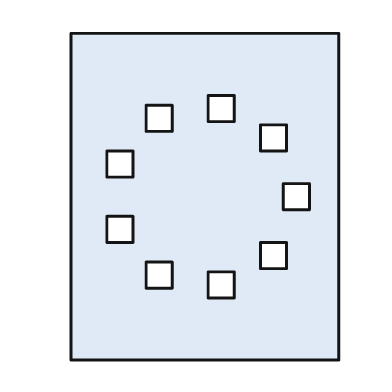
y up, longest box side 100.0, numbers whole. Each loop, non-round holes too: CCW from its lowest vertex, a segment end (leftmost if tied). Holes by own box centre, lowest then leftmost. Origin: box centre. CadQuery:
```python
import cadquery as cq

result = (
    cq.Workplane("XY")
    .moveTo(-41.0, -50.0)
    .lineTo(41.0, -50.0)
    .lineTo(41.0, 50.0)
    .lineTo(-41.0, 50.0)
    .close()
    .moveTo(1.0, -31.0)
    .lineTo(9.0, -31.0)
    .lineTo(9.0, -23.0)
    .lineTo(1.0, -23.0)
    .close()
    .moveTo(-18.0, -28.0)
    .lineTo(-10.0, -28.0)
    .lineTo(-10.0, -20.0)
    .lineTo(-18.0, -20.0)
    .close()
    .moveTo(17.0, -22.0)
    .lineTo(25.0, -22.0)
    .lineTo(25.0, -14.0)
    .lineTo(17.0, -14.0)
    .close()
    .moveTo(-30.0, -14.0)
    .lineTo(-22.0, -14.0)
    .lineTo(-22.0, -6.0)
    .lineTo(-30.0, -6.0)
    .close()
    .moveTo(24.0, -4.0)
    .lineTo(32.0, -4.0)
    .lineTo(32.0, 4.0)
    .lineTo(24.0, 4.0)
    .close()
    .moveTo(-30.0, 6.0)
    .lineTo(-22.0, 6.0)
    .lineTo(-22.0, 14.0)
    .lineTo(-30.0, 14.0)
    .close()
    .moveTo(17.0, 14.0)
    .lineTo(25.0, 14.0)
    .lineTo(25.0, 22.0)
    .lineTo(17.0, 22.0)
    .close()
    .moveTo(-18.0, 20.0)
    .lineTo(-10.0, 20.0)
    .lineTo(-10.0, 28.0)
    .lineTo(-18.0, 28.0)
    .close()
    .moveTo(1.0, 23.0)
    .lineTo(9.0, 23.0)
    .lineTo(9.0, 31.0)
    .lineTo(1.0, 31.0)
    .close()
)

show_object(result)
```